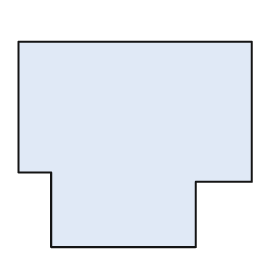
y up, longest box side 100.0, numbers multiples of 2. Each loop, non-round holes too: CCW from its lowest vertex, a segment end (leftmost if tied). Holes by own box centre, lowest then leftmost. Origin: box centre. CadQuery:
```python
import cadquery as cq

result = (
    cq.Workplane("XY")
    .moveTo(-36.0, -44.0)
    .lineTo(26.0, -44.0)
    .lineTo(26.0, -16.0)
    .lineTo(50.0, -16.0)
    .lineTo(50.0, 44.0)
    .lineTo(-50.0, 44.0)
    .lineTo(-50.0, -12.0)
    .lineTo(-36.0, -12.0)
    .close()
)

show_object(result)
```